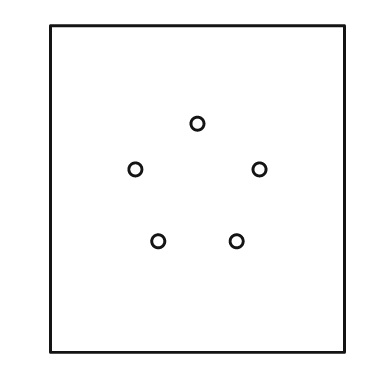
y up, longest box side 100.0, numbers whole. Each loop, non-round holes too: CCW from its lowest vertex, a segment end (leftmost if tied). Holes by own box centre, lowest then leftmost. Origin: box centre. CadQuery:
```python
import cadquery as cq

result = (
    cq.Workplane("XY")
    .moveTo(-45.0, -50.0)
    .lineTo(45.0, -50.0)
    .lineTo(45.0, 50.0)
    .lineTo(-45.0, 50.0)
    .close()
    .moveTo(-12.0, -16.0)
    .circle(2.0)
    .moveTo(12.0, -16.0)
    .circle(2.0)
    .moveTo(-19.0, 6.0)
    .circle(2.0)
    .moveTo(19.0, 6.0)
    .circle(2.0)
    .moveTo(0.0, 20.0)
    .circle(2.0)
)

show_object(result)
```